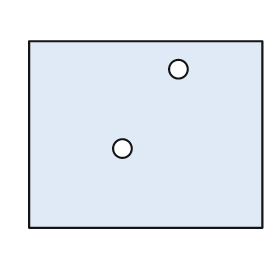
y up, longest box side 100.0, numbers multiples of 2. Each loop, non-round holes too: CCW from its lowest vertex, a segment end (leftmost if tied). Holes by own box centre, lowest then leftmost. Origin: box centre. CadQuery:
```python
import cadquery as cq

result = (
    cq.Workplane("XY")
    .moveTo(-50.0, -40.0)
    .lineTo(50.0, -40.0)
    .lineTo(50.0, 40.0)
    .lineTo(-50.0, 40.0)
    .close()
    .moveTo(-10.0, -6.0)
    .circle(4.0)
    .moveTo(14.0, 28.0)
    .circle(4.0)
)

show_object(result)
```